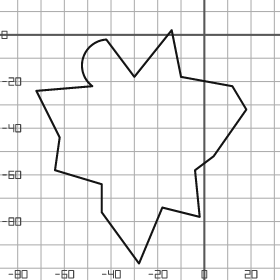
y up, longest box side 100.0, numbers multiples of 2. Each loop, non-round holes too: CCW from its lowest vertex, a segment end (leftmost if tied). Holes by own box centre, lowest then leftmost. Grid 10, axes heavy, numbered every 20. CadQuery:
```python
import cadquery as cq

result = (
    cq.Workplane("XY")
    .moveTo(-28.0, -98.0)
    .lineTo(-18.0, -74.0)
    .lineTo(-2.0, -78.0)
    .lineTo(-4.0, -58.0)
    .lineTo(4.0, -52.0)
    .lineTo(18.0, -32.0)
    .lineTo(12.0, -22.0)
    .lineTo(-10.0, -18.0)
    .lineTo(-14.0, 2.0)
    .lineTo(-30.0, -18.0)
    .lineTo(-42.0, -2.0)
    .threePointArc((-52.0, -10.0), (-48.0, -22.0))
    .lineTo(-72.0, -24.0)
    .lineTo(-62.0, -44.0)
    .lineTo(-64.0, -58.0)
    .lineTo(-44.0, -64.0)
    .lineTo(-44.0, -76.0)
    .close()
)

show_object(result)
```